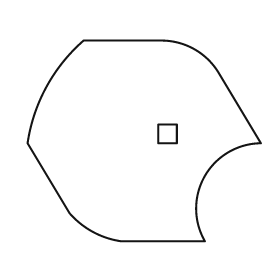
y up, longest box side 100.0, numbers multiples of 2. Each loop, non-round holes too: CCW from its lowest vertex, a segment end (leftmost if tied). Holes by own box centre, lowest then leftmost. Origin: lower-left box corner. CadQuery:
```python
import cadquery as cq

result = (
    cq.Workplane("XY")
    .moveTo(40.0, 0.0)
    .lineTo(76.0, 0.0)
    .threePointArc((76.0, 28.0), (100.0, 42.0))
    .lineTo(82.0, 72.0)
    .threePointArc((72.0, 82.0), (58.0, 86.0))
    .lineTo(24.0, 86.0)
    .threePointArc((8.0, 66.0), (0.0, 42.0))
    .lineTo(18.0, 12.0)
    .threePointArc((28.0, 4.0), (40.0, 0.0))
    .close()
    .moveTo(56.0, 42.0)
    .lineTo(64.0, 42.0)
    .lineTo(64.0, 50.0)
    .lineTo(56.0, 50.0)
    .close()
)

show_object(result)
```